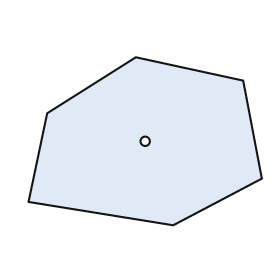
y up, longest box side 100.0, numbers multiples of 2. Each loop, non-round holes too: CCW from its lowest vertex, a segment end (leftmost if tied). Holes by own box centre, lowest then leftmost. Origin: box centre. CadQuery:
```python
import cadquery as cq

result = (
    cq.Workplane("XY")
    .moveTo(12.0, -36.0)
    .lineTo(50.0, -16.0)
    .lineTo(42.0, 26.0)
    .lineTo(-4.0, 36.0)
    .lineTo(-42.0, 12.0)
    .lineTo(-50.0, -26.0)
    .close()
    .moveTo(0.0, 0.0)
    .circle(2.0)
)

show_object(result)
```